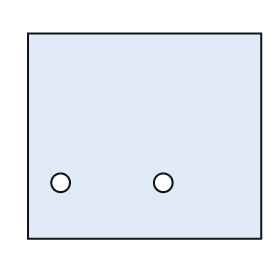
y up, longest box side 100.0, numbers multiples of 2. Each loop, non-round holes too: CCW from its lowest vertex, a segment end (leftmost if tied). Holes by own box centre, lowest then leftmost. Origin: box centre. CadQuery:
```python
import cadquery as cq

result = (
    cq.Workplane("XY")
    .moveTo(-50.0, -44.0)
    .lineTo(50.0, -44.0)
    .lineTo(50.0, 44.0)
    .lineTo(-50.0, 44.0)
    .close()
    .moveTo(-36.0, -20.0)
    .circle(4.0)
    .moveTo(8.0, -20.0)
    .circle(4.0)
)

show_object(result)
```